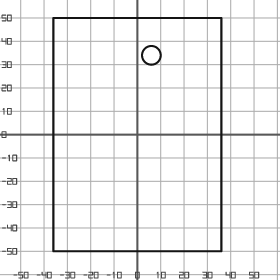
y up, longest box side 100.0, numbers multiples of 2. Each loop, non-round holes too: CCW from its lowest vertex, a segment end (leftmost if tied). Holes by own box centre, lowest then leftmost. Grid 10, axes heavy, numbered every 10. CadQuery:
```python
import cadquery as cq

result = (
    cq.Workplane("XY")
    .moveTo(-36.0, -50.0)
    .lineTo(36.0, -50.0)
    .lineTo(36.0, 50.0)
    .lineTo(-36.0, 50.0)
    .close()
    .moveTo(6.0, 34.0)
    .circle(4.0)
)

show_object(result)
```